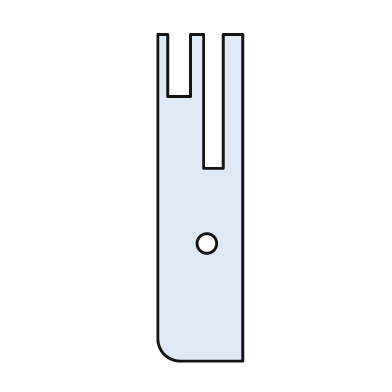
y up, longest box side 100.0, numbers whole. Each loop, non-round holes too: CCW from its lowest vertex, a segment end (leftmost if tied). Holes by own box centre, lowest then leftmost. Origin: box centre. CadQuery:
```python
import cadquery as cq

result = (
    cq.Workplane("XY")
    .moveTo(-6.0, -50.0)
    .lineTo(13.0, -50.0)
    .lineTo(13.0, 50.0)
    .lineTo(7.0, 50.0)
    .lineTo(7.0, 9.0)
    .lineTo(1.0, 9.0)
    .lineTo(1.0, 50.0)
    .lineTo(-3.0, 50.0)
    .lineTo(-3.0, 31.0)
    .lineTo(-10.0, 31.0)
    .lineTo(-10.0, 50.0)
    .lineTo(-13.0, 50.0)
    .lineTo(-13.0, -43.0)
    .threePointArc((-11.0, -48.0), (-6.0, -50.0))
    .close()
    .moveTo(2.0, -14.0)
    .circle(3.0)
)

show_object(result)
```